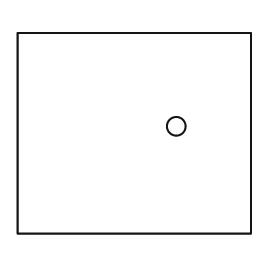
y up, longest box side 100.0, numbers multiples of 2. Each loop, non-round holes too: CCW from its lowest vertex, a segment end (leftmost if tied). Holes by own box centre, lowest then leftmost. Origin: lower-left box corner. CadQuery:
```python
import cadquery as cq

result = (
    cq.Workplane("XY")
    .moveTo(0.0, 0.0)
    .lineTo(100.0, 0.0)
    .lineTo(100.0, 86.0)
    .lineTo(0.0, 86.0)
    .close()
    .moveTo(68.0, 46.0)
    .circle(4.0)
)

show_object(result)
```